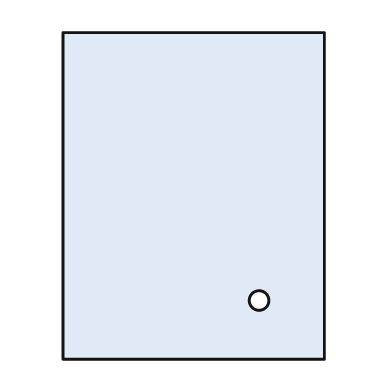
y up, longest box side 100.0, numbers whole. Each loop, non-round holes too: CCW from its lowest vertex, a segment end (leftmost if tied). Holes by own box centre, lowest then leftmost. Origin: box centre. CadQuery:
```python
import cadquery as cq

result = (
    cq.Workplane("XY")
    .moveTo(-40.0, -50.0)
    .lineTo(40.0, -50.0)
    .lineTo(40.0, 50.0)
    .lineTo(-40.0, 50.0)
    .close()
    .moveTo(20.0, -32.0)
    .circle(3.0)
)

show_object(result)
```